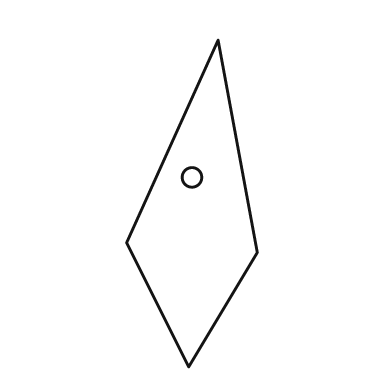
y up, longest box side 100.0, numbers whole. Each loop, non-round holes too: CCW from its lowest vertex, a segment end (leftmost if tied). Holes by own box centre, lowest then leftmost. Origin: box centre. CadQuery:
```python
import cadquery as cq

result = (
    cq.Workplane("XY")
    .moveTo(-1.0, -50.0)
    .lineTo(20.0, -15.0)
    .lineTo(8.0, 50.0)
    .lineTo(-20.0, -12.0)
    .close()
    .moveTo(0.0, 8.0)
    .circle(3.0)
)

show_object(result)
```